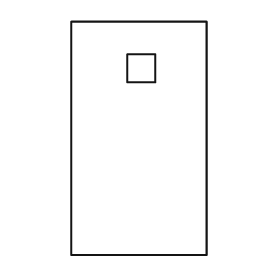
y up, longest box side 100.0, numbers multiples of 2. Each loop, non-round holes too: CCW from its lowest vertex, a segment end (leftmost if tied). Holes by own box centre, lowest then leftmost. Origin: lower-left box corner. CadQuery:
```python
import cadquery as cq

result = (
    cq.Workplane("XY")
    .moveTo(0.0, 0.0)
    .lineTo(58.0, 0.0)
    .lineTo(58.0, 100.0)
    .lineTo(0.0, 100.0)
    .close()
    .moveTo(24.0, 74.0)
    .lineTo(36.0, 74.0)
    .lineTo(36.0, 86.0)
    .lineTo(24.0, 86.0)
    .close()
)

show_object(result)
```